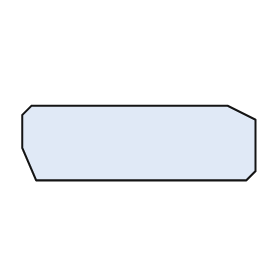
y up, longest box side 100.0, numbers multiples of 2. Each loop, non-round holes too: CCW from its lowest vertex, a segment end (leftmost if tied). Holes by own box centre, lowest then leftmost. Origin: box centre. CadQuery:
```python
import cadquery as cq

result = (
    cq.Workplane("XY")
    .moveTo(-44.0, -16.0)
    .lineTo(46.0, -16.0)
    .lineTo(50.0, -12.0)
    .lineTo(50.0, 10.0)
    .lineTo(38.0, 16.0)
    .lineTo(-46.0, 16.0)
    .lineTo(-50.0, 12.0)
    .lineTo(-50.0, -2.0)
    .close()
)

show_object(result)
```